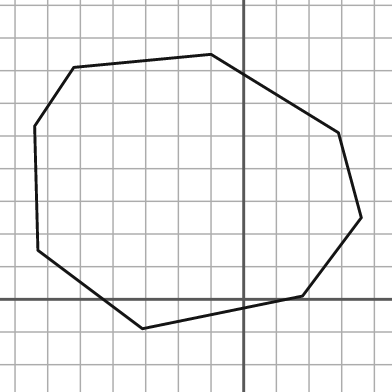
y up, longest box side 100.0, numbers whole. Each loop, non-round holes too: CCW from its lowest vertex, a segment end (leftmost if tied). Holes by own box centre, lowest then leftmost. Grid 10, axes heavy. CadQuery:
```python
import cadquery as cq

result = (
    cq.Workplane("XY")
    .moveTo(-31.0, -9.0)
    .lineTo(18.0, 1.0)
    .lineTo(36.0, 25.0)
    .lineTo(29.0, 51.0)
    .lineTo(-10.0, 75.0)
    .lineTo(-52.0, 71.0)
    .lineTo(-64.0, 53.0)
    .lineTo(-63.0, 15.0)
    .close()
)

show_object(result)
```